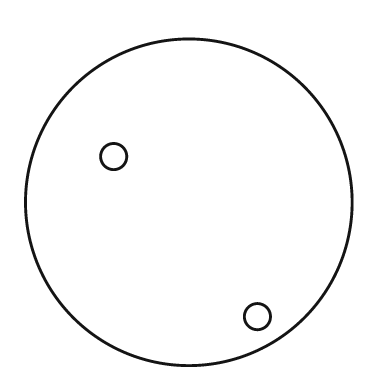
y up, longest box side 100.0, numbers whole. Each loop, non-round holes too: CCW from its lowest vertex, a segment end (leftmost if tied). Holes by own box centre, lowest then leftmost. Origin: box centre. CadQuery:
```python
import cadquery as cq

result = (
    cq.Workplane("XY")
    .moveTo(0.0, 0.0)
    .circle(50.0)
    .moveTo(21.0, -35.0)
    .circle(4.0)
    .moveTo(-23.0, 14.0)
    .circle(4.0)
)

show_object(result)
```